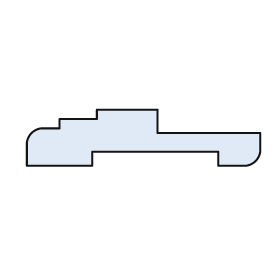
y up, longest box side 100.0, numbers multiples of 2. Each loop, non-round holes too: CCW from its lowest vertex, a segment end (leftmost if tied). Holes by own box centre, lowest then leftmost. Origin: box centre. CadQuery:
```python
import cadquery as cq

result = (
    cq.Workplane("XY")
    .moveTo(-50.0, -12.0)
    .lineTo(-22.0, -12.0)
    .lineTo(-22.0, -6.0)
    .lineTo(32.0, -6.0)
    .lineTo(32.0, -12.0)
    .lineTo(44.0, -12.0)
    .threePointArc((48.0, -10.0), (50.0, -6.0))
    .lineTo(50.0, 2.0)
    .lineTo(6.0, 2.0)
    .lineTo(6.0, 12.0)
    .lineTo(-20.0, 12.0)
    .lineTo(-20.0, 8.0)
    .lineTo(-36.0, 8.0)
    .lineTo(-36.0, 4.0)
    .lineTo(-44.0, 4.0)
    .threePointArc((-48.0, 2.0), (-50.0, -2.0))
    .close()
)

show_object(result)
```